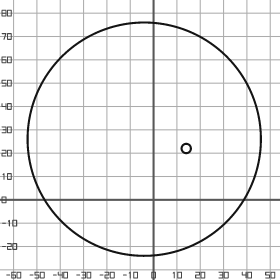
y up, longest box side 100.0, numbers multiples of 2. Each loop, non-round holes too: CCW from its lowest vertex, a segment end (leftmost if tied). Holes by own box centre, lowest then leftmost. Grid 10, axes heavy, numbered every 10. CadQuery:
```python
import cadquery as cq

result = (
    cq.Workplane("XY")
    .moveTo(-4.0, 26.0)
    .circle(50.0)
    .moveTo(14.0, 22.0)
    .circle(2.0)
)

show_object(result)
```